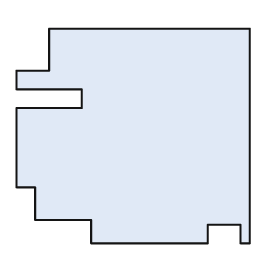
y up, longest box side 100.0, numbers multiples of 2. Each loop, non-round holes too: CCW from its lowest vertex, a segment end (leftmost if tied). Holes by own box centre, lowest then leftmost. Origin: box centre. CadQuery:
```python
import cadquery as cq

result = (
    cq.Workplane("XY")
    .moveTo(-18.0, -46.0)
    .lineTo(32.0, -46.0)
    .lineTo(32.0, -38.0)
    .lineTo(46.0, -38.0)
    .lineTo(46.0, -46.0)
    .lineTo(50.0, -46.0)
    .lineTo(50.0, 46.0)
    .lineTo(-36.0, 46.0)
    .lineTo(-36.0, 28.0)
    .lineTo(-50.0, 28.0)
    .lineTo(-50.0, 20.0)
    .lineTo(-22.0, 20.0)
    .lineTo(-22.0, 12.0)
    .lineTo(-50.0, 12.0)
    .lineTo(-50.0, -22.0)
    .lineTo(-42.0, -22.0)
    .lineTo(-42.0, -36.0)
    .lineTo(-18.0, -36.0)
    .close()
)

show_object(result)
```